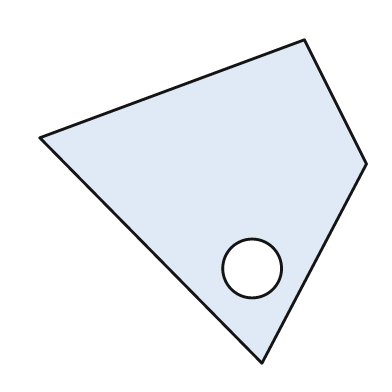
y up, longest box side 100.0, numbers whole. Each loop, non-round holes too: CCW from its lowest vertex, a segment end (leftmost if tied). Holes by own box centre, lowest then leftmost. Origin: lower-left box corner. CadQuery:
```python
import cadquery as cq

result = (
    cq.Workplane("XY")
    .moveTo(68.0, 0.0)
    .lineTo(100.0, 61.0)
    .lineTo(81.0, 99.0)
    .lineTo(0.0, 69.0)
    .close()
    .moveTo(65.0, 29.0)
    .circle(9.0)
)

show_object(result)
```